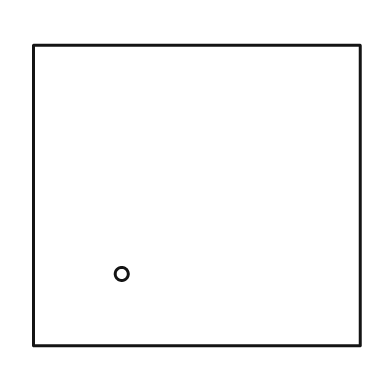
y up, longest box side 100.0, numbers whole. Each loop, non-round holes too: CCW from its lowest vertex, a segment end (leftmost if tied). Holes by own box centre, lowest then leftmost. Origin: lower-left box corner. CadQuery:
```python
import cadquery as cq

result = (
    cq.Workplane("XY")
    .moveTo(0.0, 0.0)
    .lineTo(100.0, 0.0)
    .lineTo(100.0, 92.0)
    .lineTo(0.0, 92.0)
    .close()
    .moveTo(27.0, 22.0)
    .circle(2.0)
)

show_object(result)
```